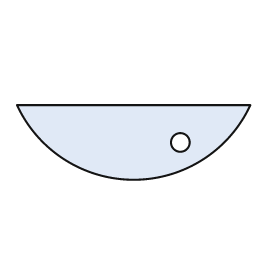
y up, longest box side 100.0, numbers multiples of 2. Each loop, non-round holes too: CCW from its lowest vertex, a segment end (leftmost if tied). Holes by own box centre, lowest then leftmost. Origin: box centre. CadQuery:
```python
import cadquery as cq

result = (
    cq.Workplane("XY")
    .moveTo(-50.0, 16.0)
    .threePointArc((0.0, -16.0), (50.0, 16.0))
    .close()
    .moveTo(20.0, 0.0)
    .circle(4.0)
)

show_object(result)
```